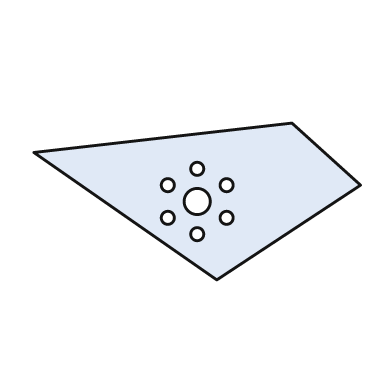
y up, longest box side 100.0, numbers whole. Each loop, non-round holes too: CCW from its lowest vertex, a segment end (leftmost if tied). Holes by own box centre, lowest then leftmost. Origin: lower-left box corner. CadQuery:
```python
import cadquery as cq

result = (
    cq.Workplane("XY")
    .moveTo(56.0, 0.0)
    .lineTo(100.0, 29.0)
    .lineTo(79.0, 48.0)
    .lineTo(0.0, 39.0)
    .close()
    .moveTo(50.0, 14.0)
    .circle(2.0)
    .moveTo(41.0, 19.0)
    .circle(2.0)
    .moveTo(59.0, 19.0)
    .circle(2.0)
    .moveTo(50.0, 24.0)
    .circle(4.0)
    .moveTo(41.0, 29.0)
    .circle(2.0)
    .moveTo(59.0, 29.0)
    .circle(2.0)
    .moveTo(50.0, 34.0)
    .circle(2.0)
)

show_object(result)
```